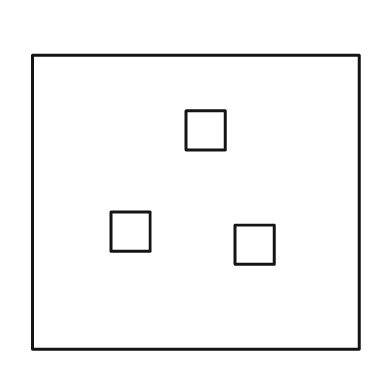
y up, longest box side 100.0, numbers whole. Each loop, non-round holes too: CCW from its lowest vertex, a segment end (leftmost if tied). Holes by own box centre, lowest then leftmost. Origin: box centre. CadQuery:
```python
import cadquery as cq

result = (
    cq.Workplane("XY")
    .moveTo(-50.0, -45.0)
    .lineTo(50.0, -45.0)
    .lineTo(50.0, 45.0)
    .lineTo(-50.0, 45.0)
    .close()
    .moveTo(12.0, -19.0)
    .lineTo(24.0, -19.0)
    .lineTo(24.0, -7.0)
    .lineTo(12.0, -7.0)
    .close()
    .moveTo(-26.0, -15.0)
    .lineTo(-14.0, -15.0)
    .lineTo(-14.0, -3.0)
    .lineTo(-26.0, -3.0)
    .close()
    .moveTo(-3.0, 16.0)
    .lineTo(9.0, 16.0)
    .lineTo(9.0, 28.0)
    .lineTo(-3.0, 28.0)
    .close()
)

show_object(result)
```